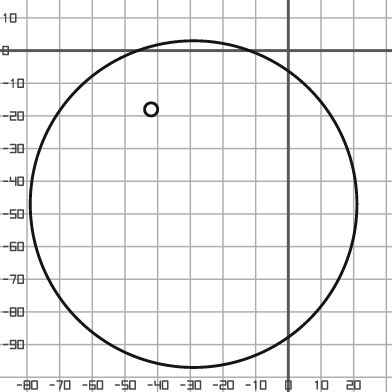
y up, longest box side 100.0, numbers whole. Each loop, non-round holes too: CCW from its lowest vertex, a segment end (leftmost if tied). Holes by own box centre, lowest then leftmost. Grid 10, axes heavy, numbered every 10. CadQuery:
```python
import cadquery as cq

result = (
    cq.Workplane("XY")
    .moveTo(-29.0, -47.0)
    .circle(50.0)
    .moveTo(-42.0, -18.0)
    .circle(2.0)
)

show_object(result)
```